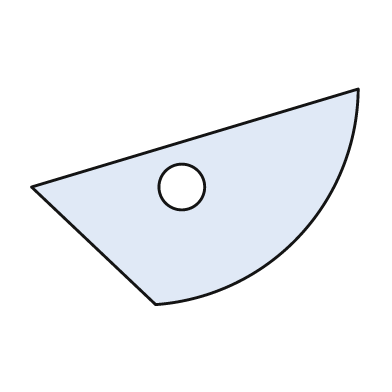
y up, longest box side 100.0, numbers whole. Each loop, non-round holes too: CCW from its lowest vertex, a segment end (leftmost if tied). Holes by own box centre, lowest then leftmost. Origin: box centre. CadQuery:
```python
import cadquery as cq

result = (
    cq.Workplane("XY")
    .moveTo(-12.0, -33.0)
    .threePointArc((32.0, -12.0), (50.0, 33.0))
    .lineTo(-50.0, 3.0)
    .close()
    .moveTo(-4.0, 3.0)
    .circle(7.0)
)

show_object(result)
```